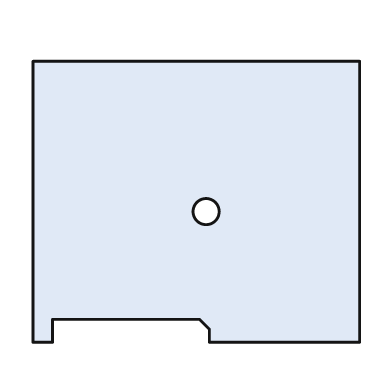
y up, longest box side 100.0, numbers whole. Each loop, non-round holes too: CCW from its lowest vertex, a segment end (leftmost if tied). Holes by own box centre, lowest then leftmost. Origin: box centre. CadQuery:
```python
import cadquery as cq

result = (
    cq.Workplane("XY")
    .moveTo(-50.0, -43.0)
    .lineTo(-44.0, -43.0)
    .lineTo(-44.0, -36.0)
    .lineTo(1.0, -36.0)
    .lineTo(4.0, -39.0)
    .lineTo(4.0, -43.0)
    .lineTo(50.0, -43.0)
    .lineTo(50.0, 43.0)
    .lineTo(-50.0, 43.0)
    .close()
    .moveTo(3.0, -3.0)
    .circle(4.0)
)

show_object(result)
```